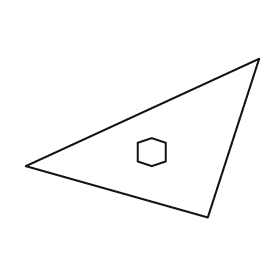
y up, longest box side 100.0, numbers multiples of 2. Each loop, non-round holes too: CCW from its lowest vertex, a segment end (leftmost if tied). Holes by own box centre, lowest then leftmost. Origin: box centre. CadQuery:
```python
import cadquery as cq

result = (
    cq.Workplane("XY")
    .moveTo(28.0, -34.0)
    .lineTo(50.0, 34.0)
    .lineTo(-50.0, -12.0)
    .close()
    .moveTo(4.0, -12.0)
    .lineTo(10.0, -10.0)
    .lineTo(10.0, -2.0)
    .lineTo(4.0, 0.0)
    .lineTo(-2.0, -2.0)
    .lineTo(-2.0, -10.0)
    .close()
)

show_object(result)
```